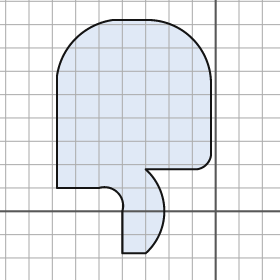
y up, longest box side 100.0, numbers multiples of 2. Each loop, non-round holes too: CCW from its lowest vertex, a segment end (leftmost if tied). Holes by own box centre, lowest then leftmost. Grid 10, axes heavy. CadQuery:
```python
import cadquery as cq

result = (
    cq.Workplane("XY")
    .moveTo(-40.0, -18.0)
    .lineTo(-30.0, -18.0)
    .threePointArc((-22.0, 0.0), (-30.0, 18.0))
    .lineTo(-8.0, 18.0)
    .threePointArc((-4.0, 20.0), (-2.0, 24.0))
    .lineTo(-2.0, 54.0)
    .threePointArc((-10.0, 74.0), (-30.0, 82.0))
    .lineTo(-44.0, 82.0)
    .threePointArc((-60.0, 74.0), (-68.0, 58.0))
    .lineTo(-68.0, 10.0)
    .lineTo(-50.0, 10.0)
    .threePointArc((-42.0, 8.0), (-40.0, 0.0))
    .close()
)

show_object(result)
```